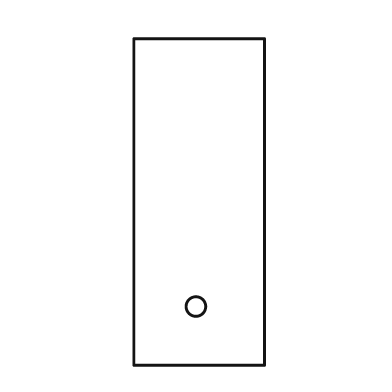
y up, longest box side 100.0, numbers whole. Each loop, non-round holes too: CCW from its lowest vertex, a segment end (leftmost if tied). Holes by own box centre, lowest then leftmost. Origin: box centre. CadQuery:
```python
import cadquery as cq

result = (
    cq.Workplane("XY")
    .moveTo(-20.0, -50.0)
    .lineTo(20.0, -50.0)
    .lineTo(20.0, 50.0)
    .lineTo(-20.0, 50.0)
    .close()
    .moveTo(-1.0, -32.0)
    .circle(3.0)
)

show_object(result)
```